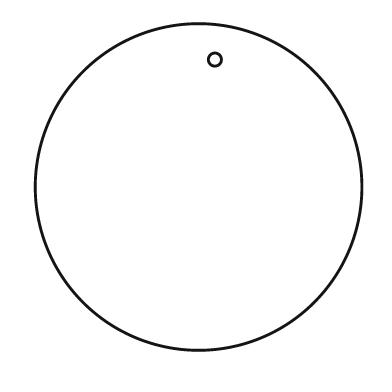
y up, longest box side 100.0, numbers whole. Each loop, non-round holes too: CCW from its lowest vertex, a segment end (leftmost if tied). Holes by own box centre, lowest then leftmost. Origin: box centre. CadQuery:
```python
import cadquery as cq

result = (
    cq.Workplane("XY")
    .moveTo(0.0, 0.0)
    .circle(50.0)
    .moveTo(5.0, 39.0)
    .circle(2.0)
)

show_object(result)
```